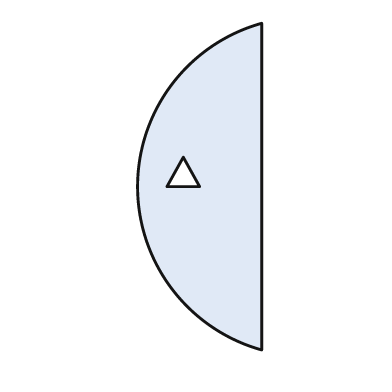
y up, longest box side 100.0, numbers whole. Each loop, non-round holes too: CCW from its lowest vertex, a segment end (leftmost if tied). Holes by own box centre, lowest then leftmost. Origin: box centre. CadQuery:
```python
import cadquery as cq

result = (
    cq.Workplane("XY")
    .moveTo(19.0, -50.0)
    .lineTo(19.0, 50.0)
    .threePointArc((-19.0, 0.0), (19.0, -50.0))
    .close()
    .moveTo(-10.0, 0.0)
    .lineTo(0.0, 0.0)
    .lineTo(-5.0, 9.0)
    .close()
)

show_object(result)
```